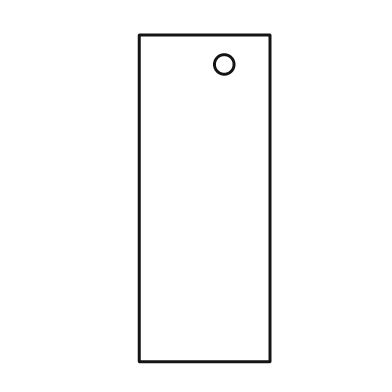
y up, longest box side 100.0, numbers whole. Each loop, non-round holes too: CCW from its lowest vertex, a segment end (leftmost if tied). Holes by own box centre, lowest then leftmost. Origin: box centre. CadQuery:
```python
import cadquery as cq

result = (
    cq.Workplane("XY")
    .moveTo(-20.0, -50.0)
    .lineTo(20.0, -50.0)
    .lineTo(20.0, 50.0)
    .lineTo(-20.0, 50.0)
    .close()
    .moveTo(6.0, 41.0)
    .circle(3.0)
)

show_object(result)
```